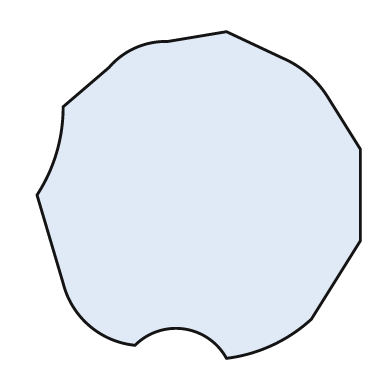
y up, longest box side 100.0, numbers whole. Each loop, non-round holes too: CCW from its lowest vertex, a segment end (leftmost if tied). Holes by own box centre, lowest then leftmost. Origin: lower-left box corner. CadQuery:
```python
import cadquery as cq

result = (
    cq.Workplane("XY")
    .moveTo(58.0, 0.0)
    .threePointArc((72.0, 4.0), (84.0, 12.0))
    .lineTo(99.0, 36.0)
    .lineTo(99.0, 64.0)
    .lineTo(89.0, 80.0)
    .threePointArc((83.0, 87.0), (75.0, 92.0))
    .lineTo(58.0, 100.0)
    .lineTo(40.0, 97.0)
    .threePointArc((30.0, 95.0), (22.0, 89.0))
    .lineTo(8.0, 77.0)
    .threePointArc((6.0, 63.0), (0.0, 50.0))
    .lineTo(8.0, 23.0)
    .threePointArc((16.0, 10.0), (30.0, 4.0))
    .threePointArc((45.0, 9.0), (58.0, 0.0))
    .close()
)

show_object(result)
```